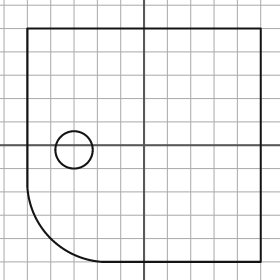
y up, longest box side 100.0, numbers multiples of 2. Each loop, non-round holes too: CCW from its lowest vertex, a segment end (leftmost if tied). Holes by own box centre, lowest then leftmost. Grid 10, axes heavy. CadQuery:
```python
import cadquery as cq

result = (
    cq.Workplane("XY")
    .moveTo(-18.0, -50.0)
    .lineTo(50.0, -50.0)
    .lineTo(50.0, 50.0)
    .lineTo(-50.0, 50.0)
    .lineTo(-50.0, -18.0)
    .threePointArc((-40.0, -40.0), (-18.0, -50.0))
    .close()
    .moveTo(-30.0, -2.0)
    .circle(8.0)
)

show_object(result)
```